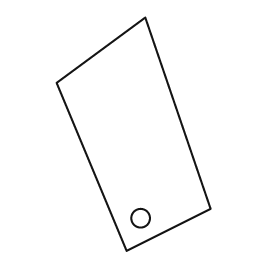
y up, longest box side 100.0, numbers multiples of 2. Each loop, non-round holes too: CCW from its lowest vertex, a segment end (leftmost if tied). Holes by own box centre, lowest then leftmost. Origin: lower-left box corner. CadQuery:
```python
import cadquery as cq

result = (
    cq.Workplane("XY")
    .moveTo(30.0, 0.0)
    .lineTo(66.0, 18.0)
    .lineTo(38.0, 100.0)
    .lineTo(0.0, 72.0)
    .close()
    .moveTo(36.0, 14.0)
    .circle(4.0)
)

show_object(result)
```